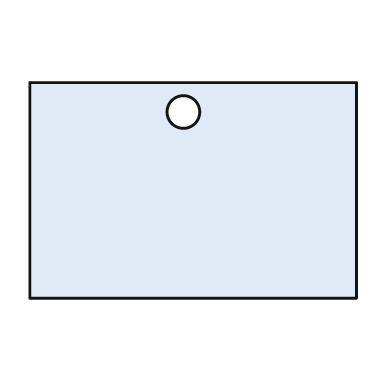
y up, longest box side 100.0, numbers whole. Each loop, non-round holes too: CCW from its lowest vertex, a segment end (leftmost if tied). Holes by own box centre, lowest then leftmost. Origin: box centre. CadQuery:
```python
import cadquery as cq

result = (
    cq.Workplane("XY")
    .moveTo(-50.0, -33.0)
    .lineTo(50.0, -33.0)
    .lineTo(50.0, 33.0)
    .lineTo(-50.0, 33.0)
    .close()
    .moveTo(-3.0, 24.0)
    .circle(5.0)
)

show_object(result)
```